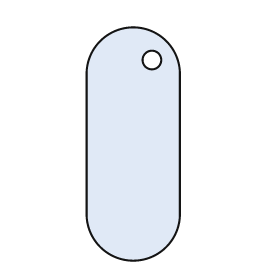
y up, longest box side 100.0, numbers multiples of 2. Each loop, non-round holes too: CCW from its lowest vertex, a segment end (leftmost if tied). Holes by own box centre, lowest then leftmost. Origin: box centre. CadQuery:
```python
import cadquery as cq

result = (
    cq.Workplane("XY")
    .moveTo(-20.0, -30.0)
    .threePointArc((0.0, -50.0), (20.0, -30.0))
    .lineTo(20.0, 30.0)
    .threePointArc((0.0, 50.0), (-20.0, 30.0))
    .close()
    .moveTo(8.0, 36.0)
    .circle(4.0)
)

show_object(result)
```